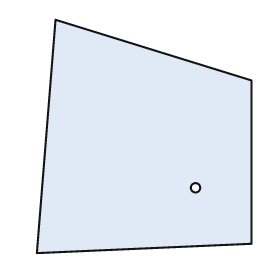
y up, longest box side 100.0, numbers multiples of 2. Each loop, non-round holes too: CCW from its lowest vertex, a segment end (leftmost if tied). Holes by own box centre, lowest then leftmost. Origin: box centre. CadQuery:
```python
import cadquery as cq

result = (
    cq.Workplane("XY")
    .moveTo(-46.0, -50.0)
    .lineTo(46.0, -46.0)
    .lineTo(46.0, 24.0)
    .lineTo(-38.0, 50.0)
    .close()
    .moveTo(22.0, -22.0)
    .circle(2.0)
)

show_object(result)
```